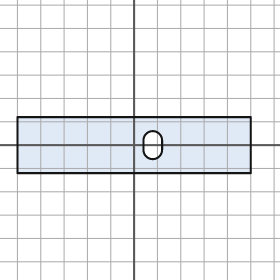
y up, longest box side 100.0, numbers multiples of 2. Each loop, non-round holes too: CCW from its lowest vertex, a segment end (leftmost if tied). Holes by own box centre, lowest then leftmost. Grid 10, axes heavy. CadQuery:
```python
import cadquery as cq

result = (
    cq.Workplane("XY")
    .moveTo(-50.0, -12.0)
    .lineTo(50.0, -12.0)
    .lineTo(50.0, 12.0)
    .lineTo(-50.0, 12.0)
    .close()
    .moveTo(4.0, -2.0)
    .threePointArc((8.0, -6.0), (12.0, -2.0))
    .lineTo(12.0, 2.0)
    .threePointArc((8.0, 6.0), (4.0, 2.0))
    .close()
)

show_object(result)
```